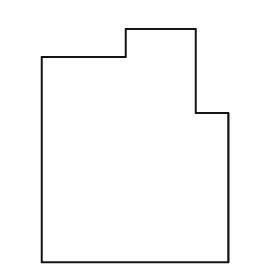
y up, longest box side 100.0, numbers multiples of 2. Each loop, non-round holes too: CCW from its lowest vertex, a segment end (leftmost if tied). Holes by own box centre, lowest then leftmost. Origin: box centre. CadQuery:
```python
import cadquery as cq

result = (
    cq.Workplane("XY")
    .moveTo(-40.0, -50.0)
    .lineTo(40.0, -50.0)
    .lineTo(40.0, 14.0)
    .lineTo(26.0, 14.0)
    .lineTo(26.0, 50.0)
    .lineTo(-4.0, 50.0)
    .lineTo(-4.0, 38.0)
    .lineTo(-40.0, 38.0)
    .close()
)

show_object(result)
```